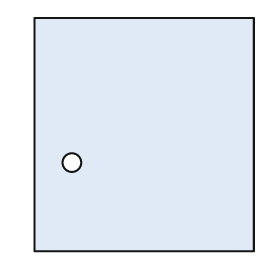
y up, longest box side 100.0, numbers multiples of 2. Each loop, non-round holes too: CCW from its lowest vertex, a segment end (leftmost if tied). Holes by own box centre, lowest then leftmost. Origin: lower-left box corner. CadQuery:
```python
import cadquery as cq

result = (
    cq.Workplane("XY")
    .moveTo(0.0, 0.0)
    .lineTo(94.0, 0.0)
    .lineTo(94.0, 100.0)
    .lineTo(0.0, 100.0)
    .close()
    .moveTo(16.0, 38.0)
    .circle(4.0)
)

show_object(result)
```